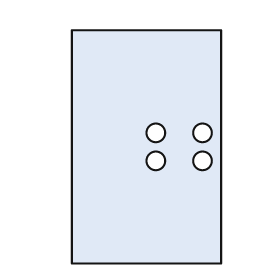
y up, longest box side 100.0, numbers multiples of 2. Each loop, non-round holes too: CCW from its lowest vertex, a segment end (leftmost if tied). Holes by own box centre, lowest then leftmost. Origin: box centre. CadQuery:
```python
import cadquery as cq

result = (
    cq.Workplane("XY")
    .moveTo(-32.0, -50.0)
    .lineTo(32.0, -50.0)
    .lineTo(32.0, 50.0)
    .lineTo(-32.0, 50.0)
    .close()
    .moveTo(4.0, -6.0)
    .circle(4.0)
    .moveTo(24.0, -6.0)
    .circle(4.0)
    .moveTo(4.0, 6.0)
    .circle(4.0)
    .moveTo(24.0, 6.0)
    .circle(4.0)
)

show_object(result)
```